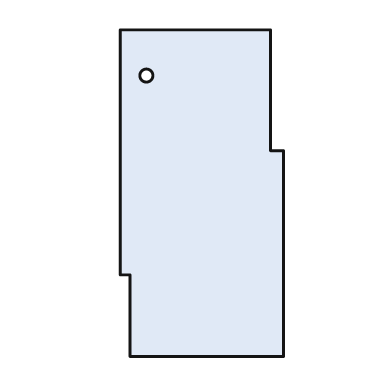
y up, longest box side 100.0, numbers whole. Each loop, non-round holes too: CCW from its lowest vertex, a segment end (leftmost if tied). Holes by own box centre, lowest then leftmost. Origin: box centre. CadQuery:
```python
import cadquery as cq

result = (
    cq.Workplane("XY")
    .moveTo(-22.0, -50.0)
    .lineTo(25.0, -50.0)
    .lineTo(25.0, 13.0)
    .lineTo(21.0, 13.0)
    .lineTo(21.0, 50.0)
    .lineTo(-25.0, 50.0)
    .lineTo(-25.0, -25.0)
    .lineTo(-22.0, -25.0)
    .close()
    .moveTo(-17.0, 36.0)
    .circle(2.0)
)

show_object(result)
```